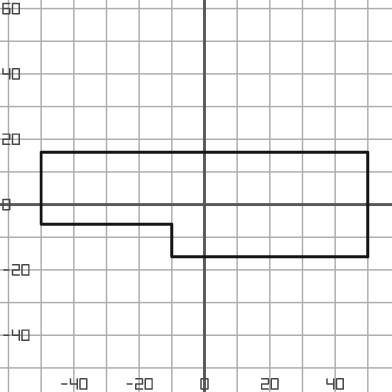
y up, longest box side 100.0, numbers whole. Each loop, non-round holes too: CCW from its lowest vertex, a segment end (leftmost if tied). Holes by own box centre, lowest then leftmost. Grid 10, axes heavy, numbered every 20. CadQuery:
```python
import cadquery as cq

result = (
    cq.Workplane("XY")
    .moveTo(-10.0, -16.0)
    .lineTo(50.0, -16.0)
    .lineTo(50.0, 16.0)
    .lineTo(-50.0, 16.0)
    .lineTo(-50.0, -6.0)
    .lineTo(-10.0, -6.0)
    .close()
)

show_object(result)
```